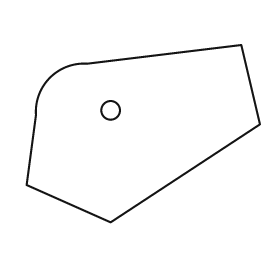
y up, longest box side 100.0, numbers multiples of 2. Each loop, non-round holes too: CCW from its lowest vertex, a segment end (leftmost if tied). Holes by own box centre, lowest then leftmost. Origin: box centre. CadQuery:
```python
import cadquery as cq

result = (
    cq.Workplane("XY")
    .moveTo(-14.0, -38.0)
    .lineTo(50.0, 4.0)
    .lineTo(42.0, 38.0)
    .lineTo(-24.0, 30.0)
    .threePointArc((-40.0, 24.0), (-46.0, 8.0))
    .lineTo(-50.0, -22.0)
    .close()
    .moveTo(-14.0, 10.0)
    .circle(4.0)
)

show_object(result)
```